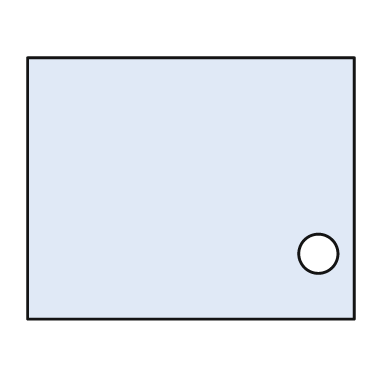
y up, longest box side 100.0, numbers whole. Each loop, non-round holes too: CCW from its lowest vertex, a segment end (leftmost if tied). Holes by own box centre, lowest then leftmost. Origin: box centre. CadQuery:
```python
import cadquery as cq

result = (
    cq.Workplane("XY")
    .moveTo(-50.0, -40.0)
    .lineTo(50.0, -40.0)
    .lineTo(50.0, 40.0)
    .lineTo(-50.0, 40.0)
    .close()
    .moveTo(39.0, -20.0)
    .circle(6.0)
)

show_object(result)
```